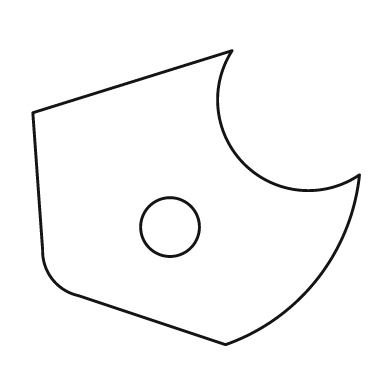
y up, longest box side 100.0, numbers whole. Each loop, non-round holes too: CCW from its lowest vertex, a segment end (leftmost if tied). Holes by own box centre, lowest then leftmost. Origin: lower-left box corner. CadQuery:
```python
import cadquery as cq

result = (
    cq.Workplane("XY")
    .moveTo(59.0, 0.0)
    .threePointArc((87.0, 20.0), (100.0, 52.0))
    .threePointArc((65.0, 55.0), (61.0, 90.0))
    .lineTo(0.0, 71.0)
    .lineTo(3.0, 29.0)
    .threePointArc((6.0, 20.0), (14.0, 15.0))
    .close()
    .moveTo(42.0, 36.0)
    .circle(9.0)
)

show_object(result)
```